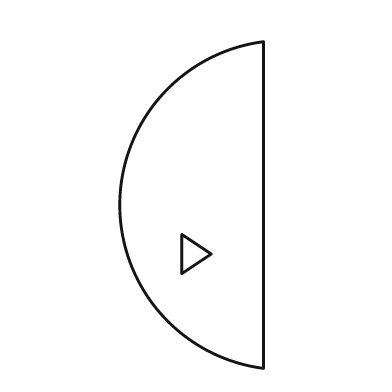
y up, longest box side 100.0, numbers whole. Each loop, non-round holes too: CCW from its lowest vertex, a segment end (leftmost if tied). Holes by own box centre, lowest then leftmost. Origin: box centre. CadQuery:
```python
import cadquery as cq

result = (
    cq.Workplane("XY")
    .moveTo(22.0, -50.0)
    .lineTo(22.0, 50.0)
    .threePointArc((-22.0, 0.0), (22.0, -50.0))
    .close()
    .moveTo(-3.0, -21.0)
    .lineTo(6.0, -15.0)
    .lineTo(-3.0, -9.0)
    .close()
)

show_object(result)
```